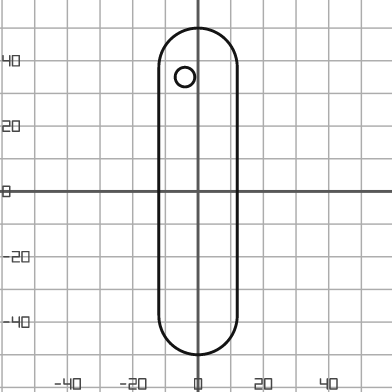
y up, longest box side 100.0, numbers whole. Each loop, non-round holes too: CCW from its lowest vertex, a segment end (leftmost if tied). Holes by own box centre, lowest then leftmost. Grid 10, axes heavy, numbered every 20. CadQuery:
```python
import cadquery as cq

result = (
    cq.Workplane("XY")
    .moveTo(-12.0, -38.0)
    .threePointArc((0.0, -50.0), (12.0, -38.0))
    .lineTo(12.0, 38.0)
    .threePointArc((0.0, 50.0), (-12.0, 38.0))
    .close()
    .moveTo(-4.0, 35.0)
    .circle(3.0)
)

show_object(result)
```